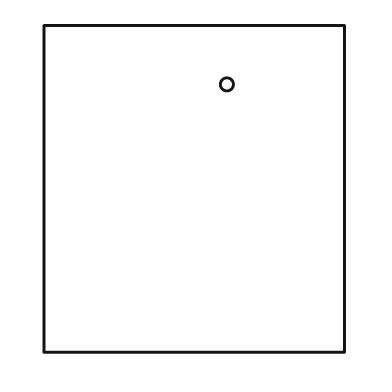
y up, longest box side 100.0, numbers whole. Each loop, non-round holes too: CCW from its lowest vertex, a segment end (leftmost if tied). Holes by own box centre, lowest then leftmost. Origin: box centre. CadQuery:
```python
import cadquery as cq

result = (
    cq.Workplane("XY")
    .moveTo(-46.0, -50.0)
    .lineTo(46.0, -50.0)
    .lineTo(46.0, 50.0)
    .lineTo(-46.0, 50.0)
    .close()
    .moveTo(10.0, 32.0)
    .circle(2.0)
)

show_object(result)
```